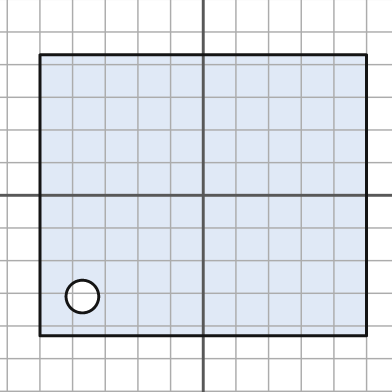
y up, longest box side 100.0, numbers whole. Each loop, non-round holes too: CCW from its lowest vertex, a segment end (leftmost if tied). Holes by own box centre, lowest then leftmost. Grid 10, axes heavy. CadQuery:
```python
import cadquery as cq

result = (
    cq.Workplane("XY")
    .moveTo(-50.0, -43.0)
    .lineTo(50.0, -43.0)
    .lineTo(50.0, 43.0)
    .lineTo(-50.0, 43.0)
    .close()
    .moveTo(-37.0, -31.0)
    .circle(5.0)
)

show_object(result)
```